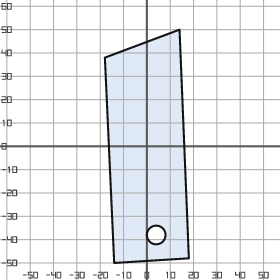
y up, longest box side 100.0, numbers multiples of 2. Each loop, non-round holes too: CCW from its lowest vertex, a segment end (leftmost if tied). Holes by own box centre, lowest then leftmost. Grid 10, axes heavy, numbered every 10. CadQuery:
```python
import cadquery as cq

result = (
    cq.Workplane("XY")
    .moveTo(-14.0, -50.0)
    .lineTo(18.0, -48.0)
    .lineTo(14.0, 50.0)
    .lineTo(-18.0, 38.0)
    .close()
    .moveTo(4.0, -38.0)
    .circle(4.0)
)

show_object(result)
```